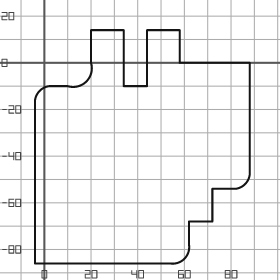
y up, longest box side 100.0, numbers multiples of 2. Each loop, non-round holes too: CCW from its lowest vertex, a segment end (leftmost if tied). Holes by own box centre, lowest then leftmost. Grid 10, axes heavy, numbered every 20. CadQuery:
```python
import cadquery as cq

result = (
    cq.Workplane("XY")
    .moveTo(-4.0, -86.0)
    .lineTo(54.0, -86.0)
    .threePointArc((60.0, -84.0), (62.0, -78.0))
    .lineTo(62.0, -68.0)
    .lineTo(72.0, -68.0)
    .lineTo(72.0, -54.0)
    .lineTo(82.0, -54.0)
    .threePointArc((86.0, -52.0), (88.0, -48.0))
    .lineTo(88.0, 0.0)
    .lineTo(58.0, 0.0)
    .lineTo(58.0, 14.0)
    .lineTo(44.0, 14.0)
    .lineTo(44.0, -10.0)
    .lineTo(34.0, -10.0)
    .lineTo(34.0, 14.0)
    .lineTo(20.0, 14.0)
    .lineTo(20.0, 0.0)
    .threePointArc((18.0, -8.0), (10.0, -10.0))
    .lineTo(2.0, -10.0)
    .threePointArc((-2.0, -12.0), (-4.0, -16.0))
    .close()
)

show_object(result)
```